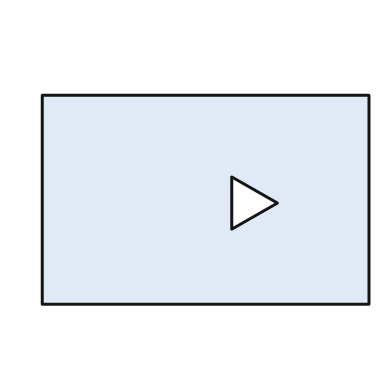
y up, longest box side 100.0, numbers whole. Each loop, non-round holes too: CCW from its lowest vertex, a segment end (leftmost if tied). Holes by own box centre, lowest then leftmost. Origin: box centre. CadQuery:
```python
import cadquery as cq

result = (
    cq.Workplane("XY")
    .moveTo(-50.0, -32.0)
    .lineTo(50.0, -32.0)
    .lineTo(50.0, 32.0)
    .lineTo(-50.0, 32.0)
    .close()
    .moveTo(8.0, -9.0)
    .lineTo(22.0, -1.0)
    .lineTo(8.0, 7.0)
    .close()
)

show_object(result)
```